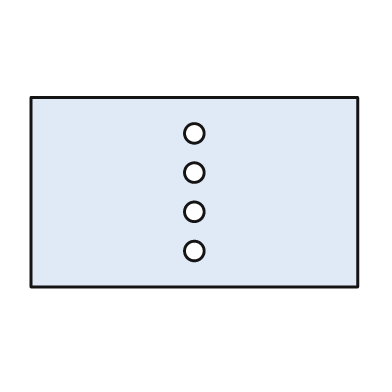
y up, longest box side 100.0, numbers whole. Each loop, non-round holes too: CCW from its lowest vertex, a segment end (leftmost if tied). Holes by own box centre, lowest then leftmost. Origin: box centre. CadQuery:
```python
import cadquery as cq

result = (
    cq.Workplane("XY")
    .moveTo(-50.0, -29.0)
    .lineTo(50.0, -29.0)
    .lineTo(50.0, 29.0)
    .lineTo(-50.0, 29.0)
    .close()
    .moveTo(0.0, -18.0)
    .circle(3.0)
    .moveTo(0.0, -6.0)
    .circle(3.0)
    .moveTo(0.0, 6.0)
    .circle(3.0)
    .moveTo(0.0, 18.0)
    .circle(3.0)
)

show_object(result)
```